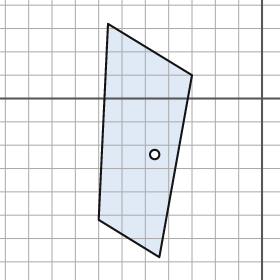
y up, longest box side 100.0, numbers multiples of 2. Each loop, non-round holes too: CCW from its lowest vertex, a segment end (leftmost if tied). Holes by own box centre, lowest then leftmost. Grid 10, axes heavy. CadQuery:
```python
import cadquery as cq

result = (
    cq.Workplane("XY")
    .moveTo(-44.0, -68.0)
    .lineTo(-30.0, 10.0)
    .lineTo(-66.0, 32.0)
    .lineTo(-70.0, -52.0)
    .close()
    .moveTo(-46.0, -24.0)
    .circle(2.0)
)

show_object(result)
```